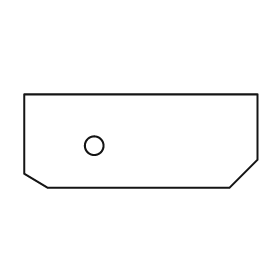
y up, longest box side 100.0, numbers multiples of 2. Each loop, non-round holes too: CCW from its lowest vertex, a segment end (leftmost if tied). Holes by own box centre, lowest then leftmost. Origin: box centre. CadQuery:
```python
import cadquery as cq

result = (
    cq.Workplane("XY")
    .moveTo(-40.0, -20.0)
    .lineTo(38.0, -20.0)
    .lineTo(50.0, -8.0)
    .lineTo(50.0, 20.0)
    .lineTo(-50.0, 20.0)
    .lineTo(-50.0, -14.0)
    .close()
    .moveTo(-20.0, -2.0)
    .circle(4.0)
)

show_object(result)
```